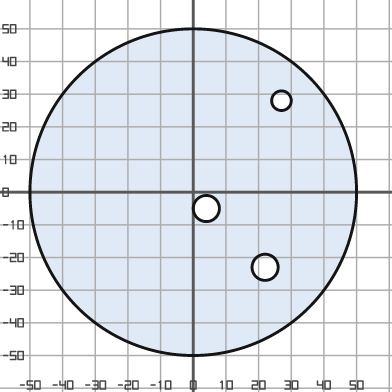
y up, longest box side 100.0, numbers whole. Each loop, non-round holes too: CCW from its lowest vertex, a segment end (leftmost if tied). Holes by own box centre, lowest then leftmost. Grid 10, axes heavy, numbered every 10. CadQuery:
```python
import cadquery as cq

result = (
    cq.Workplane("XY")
    .moveTo(0.0, 0.0)
    .circle(50.0)
    .moveTo(22.0, -23.0)
    .circle(4.0)
    .moveTo(4.0, -5.0)
    .circle(4.0)
    .moveTo(27.0, 28.0)
    .circle(3.0)
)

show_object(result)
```